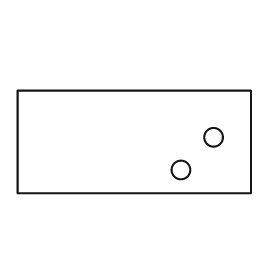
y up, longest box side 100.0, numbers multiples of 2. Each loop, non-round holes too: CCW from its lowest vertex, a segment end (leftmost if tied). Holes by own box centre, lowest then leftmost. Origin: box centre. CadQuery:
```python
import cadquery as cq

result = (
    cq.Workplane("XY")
    .moveTo(-50.0, -22.0)
    .lineTo(50.0, -22.0)
    .lineTo(50.0, 22.0)
    .lineTo(-50.0, 22.0)
    .close()
    .moveTo(20.0, -12.0)
    .circle(4.0)
    .moveTo(34.0, 2.0)
    .circle(4.0)
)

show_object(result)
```